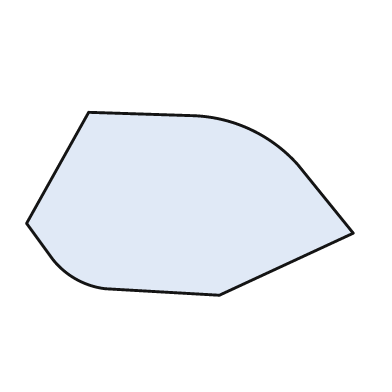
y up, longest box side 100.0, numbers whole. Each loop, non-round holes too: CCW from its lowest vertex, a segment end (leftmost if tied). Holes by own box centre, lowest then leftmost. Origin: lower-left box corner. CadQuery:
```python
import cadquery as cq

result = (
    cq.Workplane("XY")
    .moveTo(59.0, 0.0)
    .lineTo(100.0, 19.0)
    .lineTo(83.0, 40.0)
    .threePointArc((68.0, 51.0), (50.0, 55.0))
    .lineTo(19.0, 56.0)
    .lineTo(0.0, 22.0)
    .lineTo(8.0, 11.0)
    .threePointArc((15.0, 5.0), (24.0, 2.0))
    .close()
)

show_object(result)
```